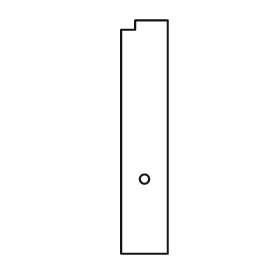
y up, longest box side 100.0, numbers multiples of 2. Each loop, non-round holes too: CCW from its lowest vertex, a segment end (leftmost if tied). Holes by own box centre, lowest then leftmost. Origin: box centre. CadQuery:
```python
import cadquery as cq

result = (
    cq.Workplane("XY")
    .moveTo(-10.0, -50.0)
    .lineTo(10.0, -50.0)
    .lineTo(10.0, 50.0)
    .lineTo(-4.0, 50.0)
    .lineTo(-4.0, 46.0)
    .lineTo(-10.0, 46.0)
    .close()
    .moveTo(0.0, -18.0)
    .circle(2.0)
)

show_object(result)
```